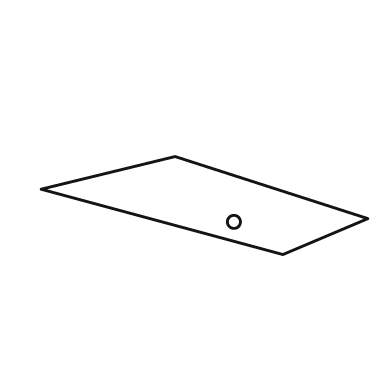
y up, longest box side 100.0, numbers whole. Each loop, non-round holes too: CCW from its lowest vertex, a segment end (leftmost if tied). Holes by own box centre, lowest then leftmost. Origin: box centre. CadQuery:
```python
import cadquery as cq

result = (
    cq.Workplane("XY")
    .moveTo(24.0, -15.0)
    .lineTo(50.0, -4.0)
    .lineTo(-9.0, 15.0)
    .lineTo(-50.0, 5.0)
    .close()
    .moveTo(9.0, -5.0)
    .circle(2.0)
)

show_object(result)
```